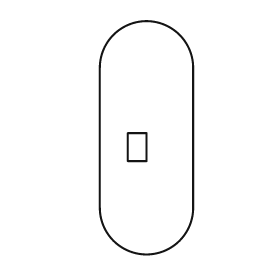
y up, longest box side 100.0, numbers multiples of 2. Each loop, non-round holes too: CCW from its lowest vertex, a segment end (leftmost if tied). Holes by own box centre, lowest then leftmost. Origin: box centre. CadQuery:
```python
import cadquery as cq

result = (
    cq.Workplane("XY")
    .moveTo(-20.0, -30.0)
    .threePointArc((0.0, -50.0), (20.0, -30.0))
    .lineTo(20.0, 30.0)
    .threePointArc((0.0, 50.0), (-20.0, 30.0))
    .close()
    .moveTo(-8.0, -10.0)
    .lineTo(0.0, -10.0)
    .lineTo(0.0, 2.0)
    .lineTo(-8.0, 2.0)
    .close()
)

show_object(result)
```